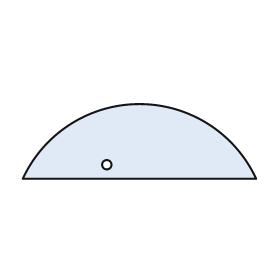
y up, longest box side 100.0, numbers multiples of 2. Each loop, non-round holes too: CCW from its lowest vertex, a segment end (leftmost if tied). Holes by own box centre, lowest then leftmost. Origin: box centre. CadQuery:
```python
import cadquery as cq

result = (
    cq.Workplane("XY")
    .moveTo(-50.0, -16.0)
    .lineTo(50.0, -16.0)
    .threePointArc((0.0, 16.0), (-50.0, -16.0))
    .close()
    .moveTo(-14.0, -10.0)
    .circle(2.0)
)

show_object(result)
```